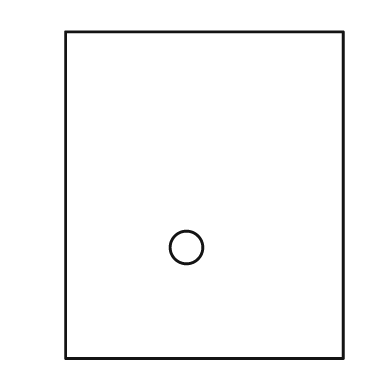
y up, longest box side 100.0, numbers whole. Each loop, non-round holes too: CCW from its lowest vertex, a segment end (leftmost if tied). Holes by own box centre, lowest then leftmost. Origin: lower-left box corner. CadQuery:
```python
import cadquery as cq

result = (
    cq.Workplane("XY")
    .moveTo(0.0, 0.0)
    .lineTo(85.0, 0.0)
    .lineTo(85.0, 100.0)
    .lineTo(0.0, 100.0)
    .close()
    .moveTo(37.0, 34.0)
    .circle(5.0)
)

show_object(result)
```